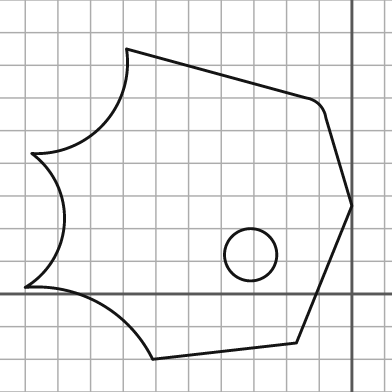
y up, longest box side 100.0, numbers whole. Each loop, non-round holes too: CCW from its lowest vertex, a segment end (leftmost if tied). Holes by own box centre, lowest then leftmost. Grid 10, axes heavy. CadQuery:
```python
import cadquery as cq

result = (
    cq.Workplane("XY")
    .moveTo(-61.0, -20.0)
    .lineTo(-17.0, -15.0)
    .lineTo(0.0, 27.0)
    .lineTo(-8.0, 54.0)
    .threePointArc((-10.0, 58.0), (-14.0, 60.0))
    .lineTo(-69.0, 75.0)
    .threePointArc((-76.0, 52.0), (-98.0, 43.0))
    .threePointArc((-88.0, 22.0), (-100.0, 2.0))
    .threePointArc((-77.0, -3.0), (-61.0, -20.0))
    .close()
    .moveTo(-31.0, 12.0)
    .circle(8.0)
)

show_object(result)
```